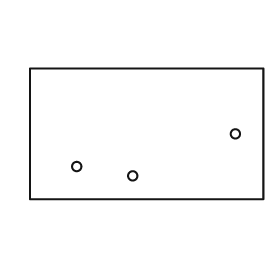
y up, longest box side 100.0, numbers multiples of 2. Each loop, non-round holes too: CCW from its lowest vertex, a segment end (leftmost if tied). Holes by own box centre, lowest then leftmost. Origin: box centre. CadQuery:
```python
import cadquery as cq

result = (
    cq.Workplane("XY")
    .moveTo(-50.0, -28.0)
    .lineTo(50.0, -28.0)
    .lineTo(50.0, 28.0)
    .lineTo(-50.0, 28.0)
    .close()
    .moveTo(-6.0, -18.0)
    .circle(2.0)
    .moveTo(-30.0, -14.0)
    .circle(2.0)
    .moveTo(38.0, 0.0)
    .circle(2.0)
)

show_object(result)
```